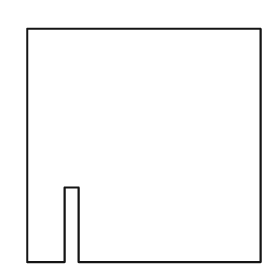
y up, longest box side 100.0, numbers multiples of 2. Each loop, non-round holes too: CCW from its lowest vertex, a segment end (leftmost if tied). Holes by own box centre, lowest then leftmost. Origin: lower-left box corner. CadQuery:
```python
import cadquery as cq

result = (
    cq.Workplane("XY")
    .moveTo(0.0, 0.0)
    .lineTo(16.0, 0.0)
    .lineTo(16.0, 32.0)
    .lineTo(22.0, 32.0)
    .lineTo(22.0, 0.0)
    .lineTo(100.0, 0.0)
    .lineTo(100.0, 100.0)
    .lineTo(0.0, 100.0)
    .close()
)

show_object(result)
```